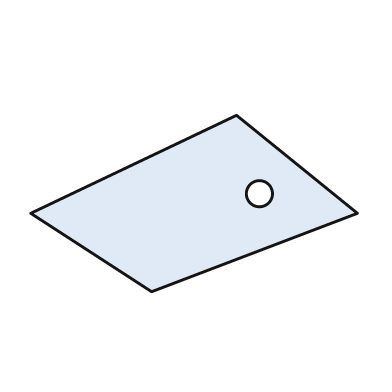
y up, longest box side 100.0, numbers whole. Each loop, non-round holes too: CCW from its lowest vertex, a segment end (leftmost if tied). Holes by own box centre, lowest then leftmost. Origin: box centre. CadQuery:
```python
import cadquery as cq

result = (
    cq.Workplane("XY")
    .moveTo(-13.0, -27.0)
    .lineTo(50.0, -3.0)
    .lineTo(13.0, 27.0)
    .lineTo(-50.0, -3.0)
    .close()
    .moveTo(20.0, 3.0)
    .circle(4.0)
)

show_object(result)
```